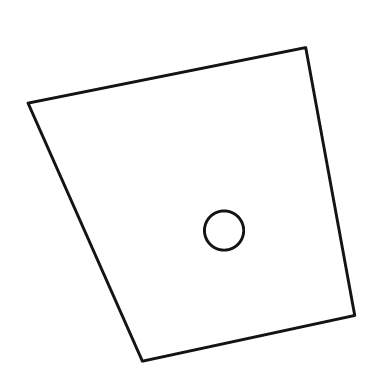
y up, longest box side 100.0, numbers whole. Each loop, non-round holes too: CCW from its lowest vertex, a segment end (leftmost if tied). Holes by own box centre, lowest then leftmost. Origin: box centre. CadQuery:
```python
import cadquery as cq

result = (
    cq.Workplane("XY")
    .moveTo(-15.0, -48.0)
    .lineTo(50.0, -34.0)
    .lineTo(35.0, 48.0)
    .lineTo(-50.0, 31.0)
    .close()
    .moveTo(10.0, -8.0)
    .circle(6.0)
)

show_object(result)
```